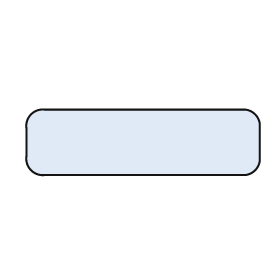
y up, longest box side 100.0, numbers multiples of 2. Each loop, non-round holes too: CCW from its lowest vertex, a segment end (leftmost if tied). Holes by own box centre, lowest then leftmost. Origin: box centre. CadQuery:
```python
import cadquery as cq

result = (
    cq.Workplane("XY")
    .moveTo(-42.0, -14.0)
    .lineTo(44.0, -14.0)
    .threePointArc((48.0, -12.0), (50.0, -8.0))
    .lineTo(50.0, 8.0)
    .threePointArc((48.0, 12.0), (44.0, 14.0))
    .lineTo(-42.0, 14.0)
    .threePointArc((-48.0, 12.0), (-50.0, 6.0))
    .lineTo(-50.0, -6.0)
    .threePointArc((-48.0, -12.0), (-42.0, -14.0))
    .close()
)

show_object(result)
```